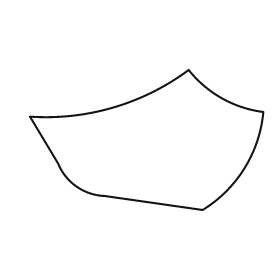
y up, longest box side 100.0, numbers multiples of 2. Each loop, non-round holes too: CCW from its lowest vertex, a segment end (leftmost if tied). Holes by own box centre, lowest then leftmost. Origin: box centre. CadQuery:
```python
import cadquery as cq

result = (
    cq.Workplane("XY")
    .moveTo(24.0, -30.0)
    .threePointArc((42.0, -12.0), (50.0, 12.0))
    .threePointArc((32.0, 18.0), (18.0, 30.0))
    .threePointArc((-14.0, 14.0), (-50.0, 10.0))
    .lineTo(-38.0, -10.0)
    .threePointArc((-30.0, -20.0), (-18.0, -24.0))
    .close()
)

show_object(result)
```